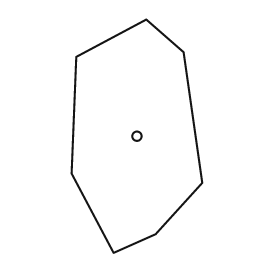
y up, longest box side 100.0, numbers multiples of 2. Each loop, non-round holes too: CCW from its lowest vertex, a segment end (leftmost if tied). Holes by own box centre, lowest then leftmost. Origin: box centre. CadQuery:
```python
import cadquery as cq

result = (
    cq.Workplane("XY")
    .moveTo(-10.0, -50.0)
    .lineTo(8.0, -42.0)
    .lineTo(28.0, -20.0)
    .lineTo(20.0, 36.0)
    .lineTo(4.0, 50.0)
    .lineTo(-26.0, 34.0)
    .lineTo(-28.0, -16.0)
    .close()
    .moveTo(0.0, 0.0)
    .circle(2.0)
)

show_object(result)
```